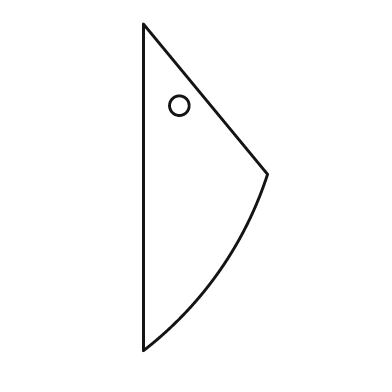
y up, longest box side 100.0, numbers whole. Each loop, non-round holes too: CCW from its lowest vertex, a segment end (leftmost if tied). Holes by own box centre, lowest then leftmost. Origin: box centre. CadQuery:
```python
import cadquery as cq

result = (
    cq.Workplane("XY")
    .moveTo(-19.0, -50.0)
    .threePointArc((4.0, -26.0), (19.0, 4.0))
    .lineTo(-19.0, 50.0)
    .close()
    .moveTo(-8.0, 25.0)
    .circle(3.0)
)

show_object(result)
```